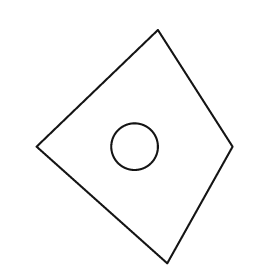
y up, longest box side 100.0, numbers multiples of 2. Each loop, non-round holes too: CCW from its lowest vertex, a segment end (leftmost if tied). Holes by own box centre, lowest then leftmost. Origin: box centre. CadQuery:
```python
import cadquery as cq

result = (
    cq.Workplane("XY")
    .moveTo(14.0, -50.0)
    .lineTo(42.0, 0.0)
    .lineTo(10.0, 50.0)
    .lineTo(-42.0, 0.0)
    .close()
    .moveTo(0.0, 0.0)
    .circle(10.0)
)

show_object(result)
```